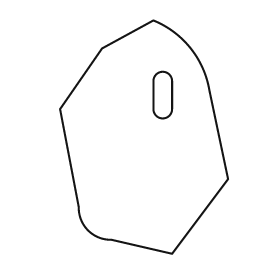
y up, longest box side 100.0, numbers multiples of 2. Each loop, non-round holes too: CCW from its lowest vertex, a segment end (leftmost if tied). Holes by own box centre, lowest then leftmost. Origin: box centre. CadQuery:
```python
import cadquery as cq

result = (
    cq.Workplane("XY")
    .moveTo(12.0, -50.0)
    .lineTo(36.0, -18.0)
    .lineTo(28.0, 20.0)
    .threePointArc((20.0, 38.0), (4.0, 50.0))
    .lineTo(-18.0, 38.0)
    .lineTo(-36.0, 12.0)
    .lineTo(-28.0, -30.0)
    .threePointArc((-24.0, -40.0), (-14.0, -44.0))
    .close()
    .moveTo(4.0, 12.0)
    .threePointArc((8.0, 8.0), (12.0, 12.0))
    .lineTo(12.0, 24.0)
    .threePointArc((8.0, 28.0), (4.0, 24.0))
    .close()
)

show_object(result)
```